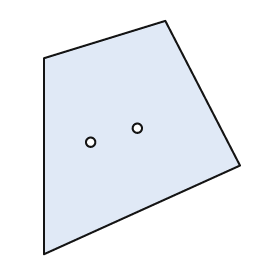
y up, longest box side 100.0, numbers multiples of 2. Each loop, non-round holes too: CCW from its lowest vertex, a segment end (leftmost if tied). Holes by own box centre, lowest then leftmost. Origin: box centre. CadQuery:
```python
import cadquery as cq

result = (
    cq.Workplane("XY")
    .moveTo(-42.0, -50.0)
    .lineTo(42.0, -12.0)
    .lineTo(10.0, 50.0)
    .lineTo(-42.0, 34.0)
    .close()
    .moveTo(-22.0, -2.0)
    .circle(2.0)
    .moveTo(-2.0, 4.0)
    .circle(2.0)
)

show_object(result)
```